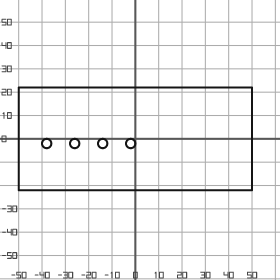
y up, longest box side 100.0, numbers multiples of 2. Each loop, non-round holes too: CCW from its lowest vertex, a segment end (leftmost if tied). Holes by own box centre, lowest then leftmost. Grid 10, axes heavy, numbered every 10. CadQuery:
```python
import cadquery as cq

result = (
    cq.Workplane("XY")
    .moveTo(-50.0, -22.0)
    .lineTo(50.0, -22.0)
    .lineTo(50.0, 22.0)
    .lineTo(-50.0, 22.0)
    .close()
    .moveTo(-38.0, -2.0)
    .circle(2.0)
    .moveTo(-26.0, -2.0)
    .circle(2.0)
    .moveTo(-14.0, -2.0)
    .circle(2.0)
    .moveTo(-2.0, -2.0)
    .circle(2.0)
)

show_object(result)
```